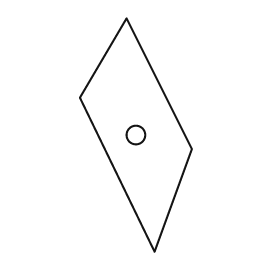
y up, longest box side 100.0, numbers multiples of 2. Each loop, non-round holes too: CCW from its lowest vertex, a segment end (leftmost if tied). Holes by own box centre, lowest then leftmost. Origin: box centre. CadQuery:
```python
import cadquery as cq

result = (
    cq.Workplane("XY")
    .moveTo(8.0, -50.0)
    .lineTo(24.0, -6.0)
    .lineTo(-4.0, 50.0)
    .lineTo(-24.0, 16.0)
    .close()
    .moveTo(0.0, 0.0)
    .circle(4.0)
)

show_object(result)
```